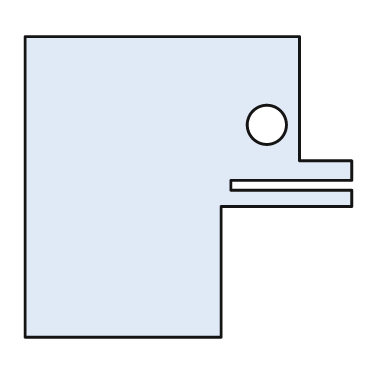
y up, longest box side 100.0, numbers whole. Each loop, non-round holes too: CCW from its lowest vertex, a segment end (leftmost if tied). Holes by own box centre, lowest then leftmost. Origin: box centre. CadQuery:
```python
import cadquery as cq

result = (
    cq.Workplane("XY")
    .moveTo(-50.0, -46.0)
    .lineTo(10.0, -46.0)
    .lineTo(10.0, -6.0)
    .lineTo(50.0, -6.0)
    .lineTo(50.0, -1.0)
    .lineTo(13.0, -1.0)
    .lineTo(13.0, 2.0)
    .lineTo(50.0, 2.0)
    .lineTo(50.0, 8.0)
    .lineTo(34.0, 8.0)
    .lineTo(34.0, 46.0)
    .lineTo(-50.0, 46.0)
    .close()
    .moveTo(24.0, 19.0)
    .circle(6.0)
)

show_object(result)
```